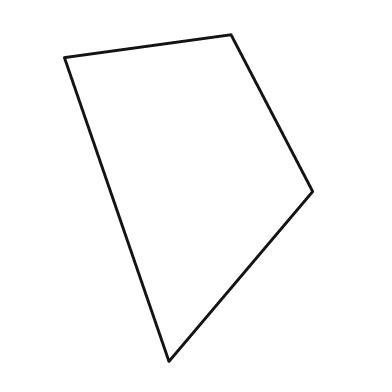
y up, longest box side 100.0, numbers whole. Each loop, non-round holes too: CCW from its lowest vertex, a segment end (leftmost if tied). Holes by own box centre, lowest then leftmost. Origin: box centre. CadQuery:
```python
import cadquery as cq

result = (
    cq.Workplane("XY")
    .moveTo(-6.0, -50.0)
    .lineTo(38.0, 2.0)
    .lineTo(13.0, 50.0)
    .lineTo(-38.0, 43.0)
    .close()
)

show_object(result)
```